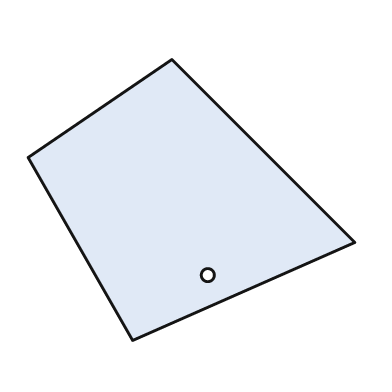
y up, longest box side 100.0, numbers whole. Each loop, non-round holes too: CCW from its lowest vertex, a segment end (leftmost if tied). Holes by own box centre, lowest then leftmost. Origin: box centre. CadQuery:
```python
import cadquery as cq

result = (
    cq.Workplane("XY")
    .moveTo(-18.0, -43.0)
    .lineTo(50.0, -13.0)
    .lineTo(-6.0, 43.0)
    .lineTo(-50.0, 13.0)
    .close()
    .moveTo(5.0, -23.0)
    .circle(2.0)
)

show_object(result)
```